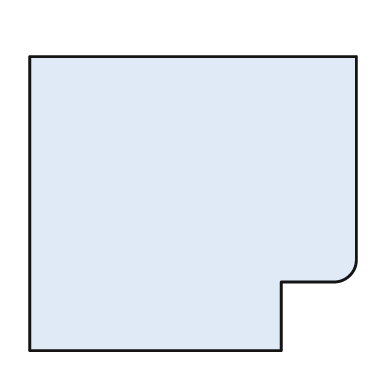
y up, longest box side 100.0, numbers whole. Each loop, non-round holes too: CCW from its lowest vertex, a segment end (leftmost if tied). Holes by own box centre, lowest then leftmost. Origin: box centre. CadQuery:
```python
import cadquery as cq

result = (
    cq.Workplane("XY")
    .moveTo(-50.0, -45.0)
    .lineTo(27.0, -45.0)
    .lineTo(27.0, -24.0)
    .lineTo(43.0, -24.0)
    .threePointArc((48.0, -22.0), (50.0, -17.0))
    .lineTo(50.0, 45.0)
    .lineTo(-50.0, 45.0)
    .close()
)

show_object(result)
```